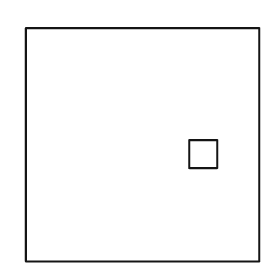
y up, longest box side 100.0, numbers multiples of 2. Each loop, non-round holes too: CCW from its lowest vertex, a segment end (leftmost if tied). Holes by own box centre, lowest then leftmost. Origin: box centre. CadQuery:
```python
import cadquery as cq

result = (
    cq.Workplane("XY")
    .moveTo(-50.0, -50.0)
    .lineTo(50.0, -50.0)
    .lineTo(50.0, 50.0)
    .lineTo(-50.0, 50.0)
    .close()
    .moveTo(20.0, -10.0)
    .lineTo(32.0, -10.0)
    .lineTo(32.0, 2.0)
    .lineTo(20.0, 2.0)
    .close()
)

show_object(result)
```